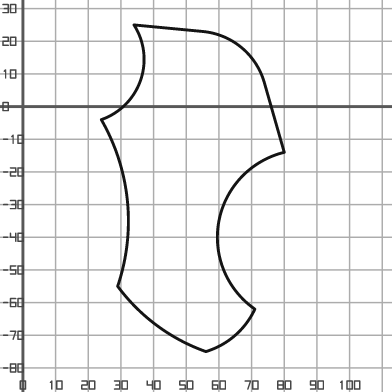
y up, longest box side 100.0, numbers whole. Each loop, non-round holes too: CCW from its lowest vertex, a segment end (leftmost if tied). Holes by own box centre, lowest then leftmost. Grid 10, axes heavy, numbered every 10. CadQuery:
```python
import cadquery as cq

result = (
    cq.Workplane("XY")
    .moveTo(56.0, -75.0)
    .threePointArc((65.0, -70.0), (71.0, -62.0))
    .threePointArc((60.0, -35.0), (80.0, -14.0))
    .lineTo(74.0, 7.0)
    .threePointArc((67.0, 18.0), (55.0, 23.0))
    .lineTo(34.0, 25.0)
    .threePointArc((36.0, 8.0), (24.0, -4.0))
    .threePointArc((32.0, -29.0), (29.0, -55.0))
    .threePointArc((41.0, -67.0), (56.0, -75.0))
    .close()
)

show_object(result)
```